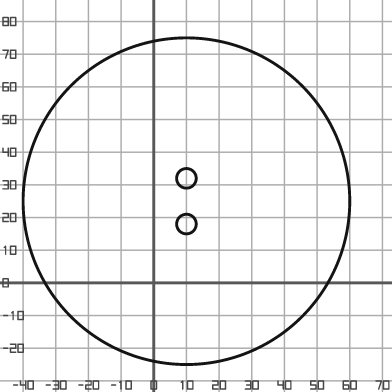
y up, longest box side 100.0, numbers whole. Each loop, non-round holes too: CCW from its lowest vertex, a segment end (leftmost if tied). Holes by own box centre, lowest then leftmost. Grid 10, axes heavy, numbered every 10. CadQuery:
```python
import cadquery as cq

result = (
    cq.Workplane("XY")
    .moveTo(10.0, 25.0)
    .circle(50.0)
    .moveTo(10.0, 18.0)
    .circle(3.0)
    .moveTo(10.0, 32.0)
    .circle(3.0)
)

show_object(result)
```